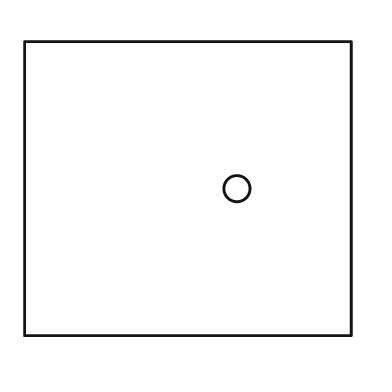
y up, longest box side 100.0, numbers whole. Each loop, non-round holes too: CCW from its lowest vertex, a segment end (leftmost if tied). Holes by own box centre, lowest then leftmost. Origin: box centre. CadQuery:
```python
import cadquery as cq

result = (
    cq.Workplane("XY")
    .moveTo(-50.0, -45.0)
    .lineTo(50.0, -45.0)
    .lineTo(50.0, 45.0)
    .lineTo(-50.0, 45.0)
    .close()
    .moveTo(15.0, 0.0)
    .circle(4.0)
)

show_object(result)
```